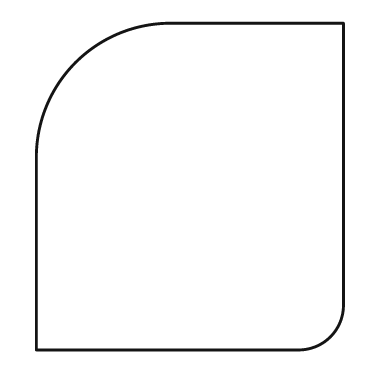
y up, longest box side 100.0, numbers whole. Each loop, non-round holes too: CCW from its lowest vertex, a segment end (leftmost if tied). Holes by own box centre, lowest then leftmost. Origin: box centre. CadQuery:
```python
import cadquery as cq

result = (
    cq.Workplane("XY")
    .moveTo(-47.0, -50.0)
    .lineTo(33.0, -50.0)
    .threePointArc((43.0, -46.0), (47.0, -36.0))
    .lineTo(47.0, 50.0)
    .lineTo(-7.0, 50.0)
    .threePointArc((-35.0, 38.0), (-47.0, 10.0))
    .close()
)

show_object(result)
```